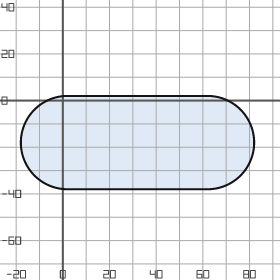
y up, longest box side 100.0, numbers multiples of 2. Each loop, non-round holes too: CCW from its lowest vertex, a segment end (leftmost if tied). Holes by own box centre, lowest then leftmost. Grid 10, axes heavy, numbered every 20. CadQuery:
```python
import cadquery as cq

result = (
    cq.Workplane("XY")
    .moveTo(2.0, -38.0)
    .lineTo(62.0, -38.0)
    .threePointArc((82.0, -18.0), (62.0, 2.0))
    .lineTo(2.0, 2.0)
    .threePointArc((-18.0, -18.0), (2.0, -38.0))
    .close()
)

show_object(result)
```